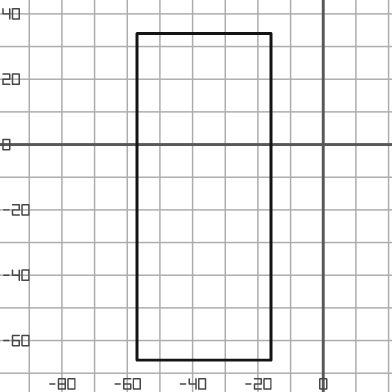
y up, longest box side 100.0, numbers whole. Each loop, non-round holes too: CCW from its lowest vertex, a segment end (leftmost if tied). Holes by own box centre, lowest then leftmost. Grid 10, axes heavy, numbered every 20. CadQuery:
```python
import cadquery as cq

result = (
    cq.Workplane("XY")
    .moveTo(-57.0, -66.0)
    .lineTo(-16.0, -66.0)
    .lineTo(-16.0, 34.0)
    .lineTo(-57.0, 34.0)
    .close()
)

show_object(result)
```